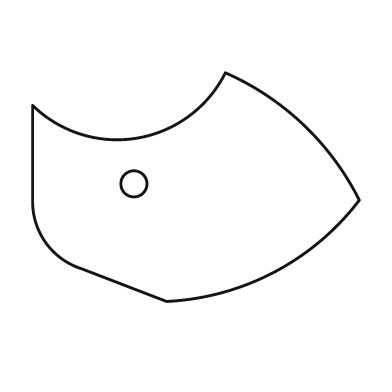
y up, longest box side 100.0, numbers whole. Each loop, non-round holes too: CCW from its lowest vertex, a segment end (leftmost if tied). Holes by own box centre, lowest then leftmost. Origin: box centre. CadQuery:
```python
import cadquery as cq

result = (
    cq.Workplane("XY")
    .moveTo(-9.0, -35.0)
    .threePointArc((24.0, -26.0), (50.0, -4.0))
    .threePointArc((33.0, 19.0), (9.0, 35.0))
    .threePointArc((-18.0, 15.0), (-50.0, 25.0))
    .lineTo(-50.0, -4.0)
    .threePointArc((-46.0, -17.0), (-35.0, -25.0))
    .close()
    .moveTo(-19.0, 1.0)
    .circle(4.0)
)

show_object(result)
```